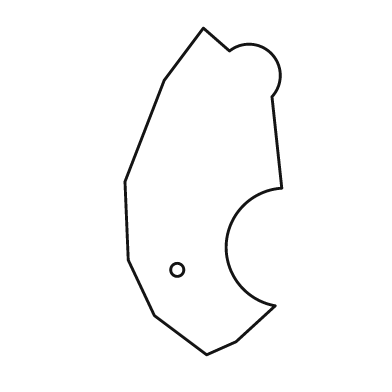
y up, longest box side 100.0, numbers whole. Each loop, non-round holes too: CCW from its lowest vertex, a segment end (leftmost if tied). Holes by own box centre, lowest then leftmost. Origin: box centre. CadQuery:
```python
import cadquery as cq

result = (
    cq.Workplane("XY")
    .moveTo(1.0, -50.0)
    .lineTo(10.0, -46.0)
    .lineTo(22.0, -35.0)
    .threePointArc((7.0, -16.0), (24.0, 1.0))
    .lineTo(21.0, 29.0)
    .threePointArc((21.0, 42.0), (8.0, 43.0))
    .lineTo(0.0, 50.0)
    .lineTo(-12.0, 34.0)
    .lineTo(-24.0, 3.0)
    .lineTo(-23.0, -21.0)
    .lineTo(-15.0, -38.0)
    .close()
    .moveTo(-8.0, -24.0)
    .circle(2.0)
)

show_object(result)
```